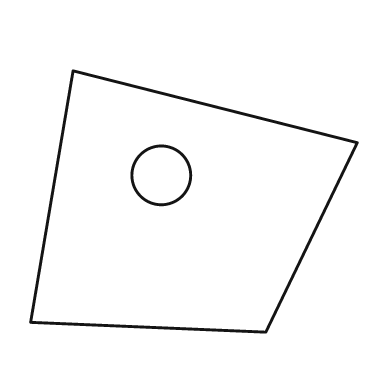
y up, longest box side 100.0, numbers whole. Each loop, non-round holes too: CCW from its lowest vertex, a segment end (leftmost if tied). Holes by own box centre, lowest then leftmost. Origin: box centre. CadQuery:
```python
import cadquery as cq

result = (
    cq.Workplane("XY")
    .moveTo(22.0, -40.0)
    .lineTo(50.0, 18.0)
    .lineTo(-37.0, 40.0)
    .lineTo(-50.0, -37.0)
    .close()
    .moveTo(-10.0, 8.0)
    .circle(9.0)
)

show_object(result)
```